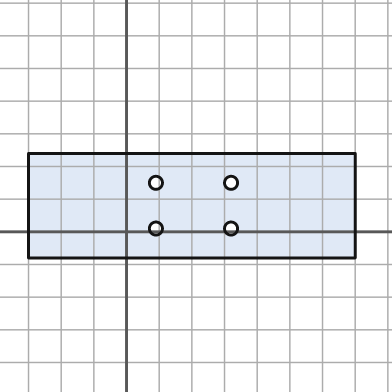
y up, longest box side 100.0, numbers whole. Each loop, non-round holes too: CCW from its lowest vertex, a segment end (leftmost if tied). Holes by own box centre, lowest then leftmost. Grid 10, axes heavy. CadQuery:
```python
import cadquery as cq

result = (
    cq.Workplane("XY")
    .moveTo(-30.0, -8.0)
    .lineTo(70.0, -8.0)
    .lineTo(70.0, 24.0)
    .lineTo(-30.0, 24.0)
    .close()
    .moveTo(9.0, 1.0)
    .circle(2.0)
    .moveTo(32.0, 1.0)
    .circle(2.0)
    .moveTo(9.0, 15.0)
    .circle(2.0)
    .moveTo(32.0, 15.0)
    .circle(2.0)
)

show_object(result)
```